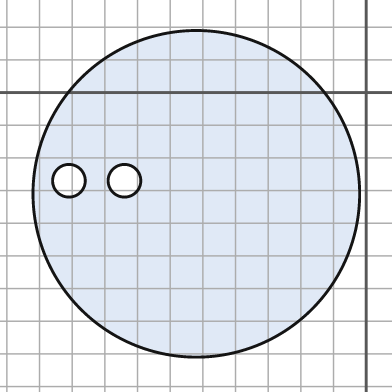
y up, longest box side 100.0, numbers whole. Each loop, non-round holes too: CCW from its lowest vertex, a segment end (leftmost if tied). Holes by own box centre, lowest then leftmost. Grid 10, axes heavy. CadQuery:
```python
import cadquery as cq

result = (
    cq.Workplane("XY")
    .moveTo(-52.0, -31.0)
    .circle(50.0)
    .moveTo(-91.0, -27.0)
    .circle(5.0)
    .moveTo(-74.0, -27.0)
    .circle(5.0)
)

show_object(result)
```